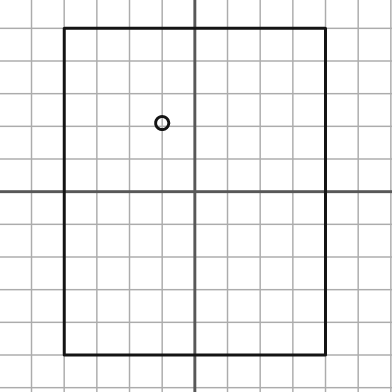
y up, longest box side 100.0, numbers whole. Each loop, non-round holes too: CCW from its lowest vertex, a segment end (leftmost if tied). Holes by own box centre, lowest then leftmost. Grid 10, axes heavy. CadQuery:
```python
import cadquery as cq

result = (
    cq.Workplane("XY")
    .moveTo(-40.0, -50.0)
    .lineTo(40.0, -50.0)
    .lineTo(40.0, 50.0)
    .lineTo(-40.0, 50.0)
    .close()
    .moveTo(-10.0, 21.0)
    .circle(2.0)
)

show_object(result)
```